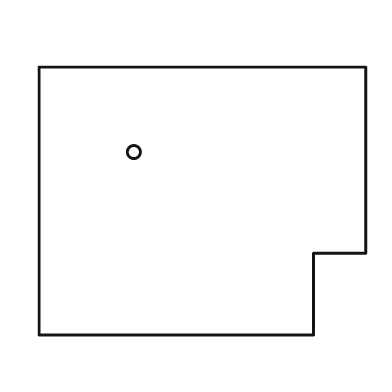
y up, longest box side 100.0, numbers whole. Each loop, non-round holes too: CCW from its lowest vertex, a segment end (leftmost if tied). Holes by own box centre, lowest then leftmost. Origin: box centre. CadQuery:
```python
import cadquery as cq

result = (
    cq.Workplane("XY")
    .moveTo(-50.0, -41.0)
    .lineTo(34.0, -41.0)
    .lineTo(34.0, -16.0)
    .lineTo(50.0, -16.0)
    .lineTo(50.0, 41.0)
    .lineTo(-50.0, 41.0)
    .close()
    .moveTo(-21.0, 15.0)
    .circle(2.0)
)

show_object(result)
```